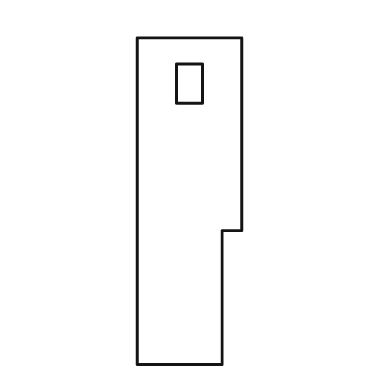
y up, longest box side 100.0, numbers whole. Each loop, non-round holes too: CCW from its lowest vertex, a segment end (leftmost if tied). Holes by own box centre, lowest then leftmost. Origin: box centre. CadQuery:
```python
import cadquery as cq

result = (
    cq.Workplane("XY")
    .moveTo(-16.0, -50.0)
    .lineTo(10.0, -50.0)
    .lineTo(10.0, -9.0)
    .lineTo(16.0, -9.0)
    .lineTo(16.0, 50.0)
    .lineTo(-16.0, 50.0)
    .close()
    .moveTo(-4.0, 30.0)
    .lineTo(4.0, 30.0)
    .lineTo(4.0, 42.0)
    .lineTo(-4.0, 42.0)
    .close()
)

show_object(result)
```